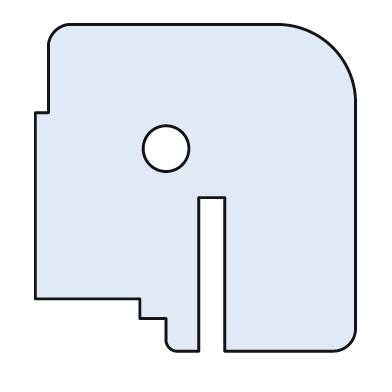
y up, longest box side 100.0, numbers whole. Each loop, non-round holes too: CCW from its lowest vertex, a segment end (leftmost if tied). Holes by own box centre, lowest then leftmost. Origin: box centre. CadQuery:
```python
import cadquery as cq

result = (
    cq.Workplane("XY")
    .moveTo(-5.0, -50.0)
    .lineTo(1.0, -50.0)
    .lineTo(1.0, -3.0)
    .lineTo(9.0, -3.0)
    .lineTo(9.0, -50.0)
    .lineTo(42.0, -50.0)
    .threePointArc((47.0, -48.0), (49.0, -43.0))
    .lineTo(49.0, 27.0)
    .threePointArc((42.0, 43.0), (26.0, 50.0))
    .lineTo(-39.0, 50.0)
    .threePointArc((-43.0, 48.0), (-45.0, 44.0))
    .lineTo(-45.0, 23.0)
    .lineTo(-49.0, 23.0)
    .lineTo(-49.0, -34.0)
    .lineTo(-17.0, -34.0)
    .lineTo(-17.0, -40.0)
    .lineTo(-9.0, -40.0)
    .lineTo(-9.0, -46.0)
    .threePointArc((-8.0, -49.0), (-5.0, -50.0))
    .close()
    .moveTo(-9.0, 12.0)
    .circle(7.0)
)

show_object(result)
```